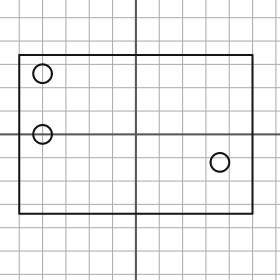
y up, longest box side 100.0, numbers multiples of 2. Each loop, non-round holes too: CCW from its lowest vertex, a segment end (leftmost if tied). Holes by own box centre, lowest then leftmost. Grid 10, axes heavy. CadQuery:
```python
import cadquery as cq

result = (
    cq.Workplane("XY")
    .moveTo(-50.0, -34.0)
    .lineTo(50.0, -34.0)
    .lineTo(50.0, 34.0)
    .lineTo(-50.0, 34.0)
    .close()
    .moveTo(36.0, -12.0)
    .circle(4.0)
    .moveTo(-40.0, 0.0)
    .circle(4.0)
    .moveTo(-40.0, 26.0)
    .circle(4.0)
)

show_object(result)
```